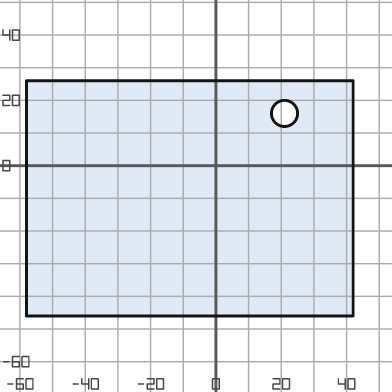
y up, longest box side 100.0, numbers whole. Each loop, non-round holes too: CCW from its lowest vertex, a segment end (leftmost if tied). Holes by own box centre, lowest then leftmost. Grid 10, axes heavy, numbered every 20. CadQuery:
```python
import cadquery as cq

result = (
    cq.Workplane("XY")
    .moveTo(-58.0, -46.0)
    .lineTo(42.0, -46.0)
    .lineTo(42.0, 26.0)
    .lineTo(-58.0, 26.0)
    .close()
    .moveTo(21.0, 16.0)
    .circle(4.0)
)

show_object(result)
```